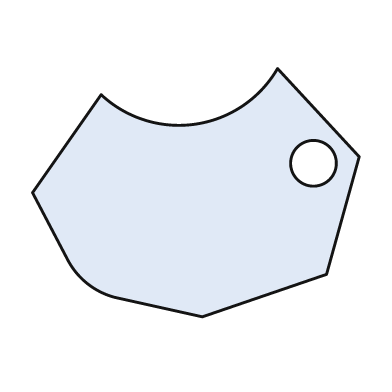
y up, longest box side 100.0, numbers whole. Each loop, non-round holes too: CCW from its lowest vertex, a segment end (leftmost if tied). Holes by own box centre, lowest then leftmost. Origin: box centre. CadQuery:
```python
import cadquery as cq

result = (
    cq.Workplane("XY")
    .moveTo(2.0, -38.0)
    .lineTo(40.0, -25.0)
    .lineTo(50.0, 11.0)
    .lineTo(25.0, 38.0)
    .threePointArc((0.0, 21.0), (-29.0, 30.0))
    .lineTo(-50.0, 0.0)
    .lineTo(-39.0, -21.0)
    .threePointArc((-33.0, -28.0), (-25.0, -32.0))
    .close()
    .moveTo(36.0, 9.0)
    .circle(7.0)
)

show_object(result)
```